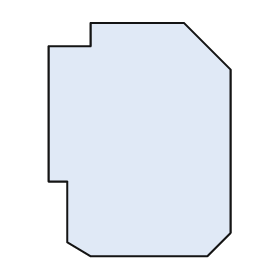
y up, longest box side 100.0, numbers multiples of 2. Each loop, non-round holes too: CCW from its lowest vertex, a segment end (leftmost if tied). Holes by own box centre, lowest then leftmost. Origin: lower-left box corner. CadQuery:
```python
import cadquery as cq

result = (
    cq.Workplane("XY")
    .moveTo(18.0, 0.0)
    .lineTo(68.0, 0.0)
    .lineTo(78.0, 10.0)
    .lineTo(78.0, 80.0)
    .lineTo(58.0, 100.0)
    .lineTo(18.0, 100.0)
    .lineTo(18.0, 90.0)
    .lineTo(0.0, 90.0)
    .lineTo(0.0, 32.0)
    .lineTo(8.0, 32.0)
    .lineTo(8.0, 6.0)
    .close()
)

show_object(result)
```